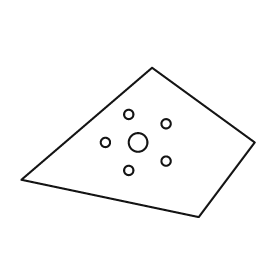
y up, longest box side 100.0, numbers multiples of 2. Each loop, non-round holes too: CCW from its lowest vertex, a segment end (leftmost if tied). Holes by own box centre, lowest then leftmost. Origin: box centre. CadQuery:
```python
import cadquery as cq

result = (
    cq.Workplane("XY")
    .moveTo(26.0, -32.0)
    .lineTo(50.0, 0.0)
    .lineTo(6.0, 32.0)
    .lineTo(-50.0, -16.0)
    .close()
    .moveTo(-4.0, -12.0)
    .circle(2.0)
    .moveTo(12.0, -8.0)
    .circle(2.0)
    .moveTo(-14.0, 0.0)
    .circle(2.0)
    .moveTo(0.0, 0.0)
    .circle(4.0)
    .moveTo(12.0, 8.0)
    .circle(2.0)
    .moveTo(-4.0, 12.0)
    .circle(2.0)
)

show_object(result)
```